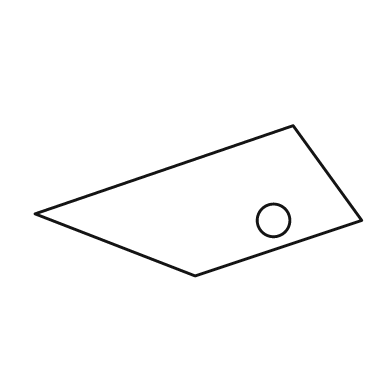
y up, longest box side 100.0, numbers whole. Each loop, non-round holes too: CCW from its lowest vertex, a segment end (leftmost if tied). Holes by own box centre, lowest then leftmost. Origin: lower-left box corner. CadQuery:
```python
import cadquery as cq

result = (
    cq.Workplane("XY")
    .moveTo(49.0, 0.0)
    .lineTo(100.0, 17.0)
    .lineTo(79.0, 46.0)
    .lineTo(0.0, 19.0)
    .close()
    .moveTo(73.0, 17.0)
    .circle(5.0)
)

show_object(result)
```